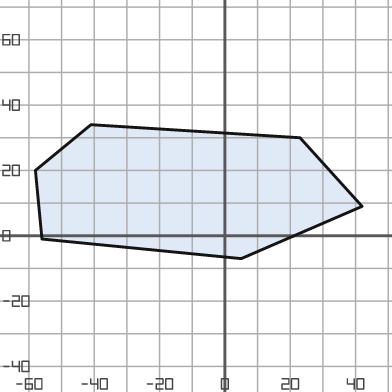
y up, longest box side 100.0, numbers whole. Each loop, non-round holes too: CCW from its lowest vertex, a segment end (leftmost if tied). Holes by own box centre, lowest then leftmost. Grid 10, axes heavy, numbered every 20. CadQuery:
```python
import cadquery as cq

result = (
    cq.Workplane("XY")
    .moveTo(5.0, -7.0)
    .lineTo(42.0, 9.0)
    .lineTo(23.0, 30.0)
    .lineTo(-41.0, 34.0)
    .lineTo(-58.0, 20.0)
    .lineTo(-56.0, -1.0)
    .close()
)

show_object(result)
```